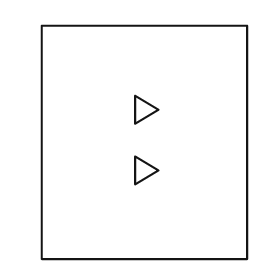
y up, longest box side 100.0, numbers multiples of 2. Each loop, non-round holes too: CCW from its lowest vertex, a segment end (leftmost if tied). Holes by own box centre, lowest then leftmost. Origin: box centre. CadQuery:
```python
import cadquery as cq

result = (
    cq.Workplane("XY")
    .moveTo(-44.0, -50.0)
    .lineTo(44.0, -50.0)
    .lineTo(44.0, 50.0)
    .lineTo(-44.0, 50.0)
    .close()
    .moveTo(-4.0, -18.0)
    .lineTo(6.0, -12.0)
    .lineTo(-4.0, -6.0)
    .close()
    .moveTo(-4.0, 8.0)
    .lineTo(6.0, 14.0)
    .lineTo(-4.0, 20.0)
    .close()
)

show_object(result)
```